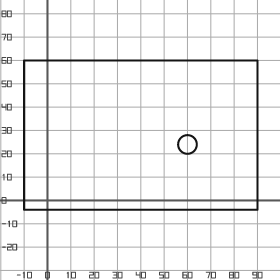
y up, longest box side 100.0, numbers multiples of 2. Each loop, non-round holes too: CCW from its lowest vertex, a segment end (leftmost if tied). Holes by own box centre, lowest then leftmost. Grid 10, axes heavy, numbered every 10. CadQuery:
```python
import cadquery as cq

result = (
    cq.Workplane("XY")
    .moveTo(-10.0, -4.0)
    .lineTo(90.0, -4.0)
    .lineTo(90.0, 60.0)
    .lineTo(-10.0, 60.0)
    .close()
    .moveTo(60.0, 24.0)
    .circle(4.0)
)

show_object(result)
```